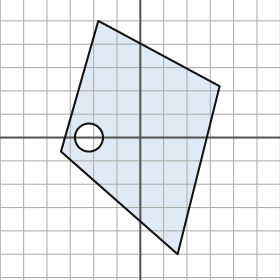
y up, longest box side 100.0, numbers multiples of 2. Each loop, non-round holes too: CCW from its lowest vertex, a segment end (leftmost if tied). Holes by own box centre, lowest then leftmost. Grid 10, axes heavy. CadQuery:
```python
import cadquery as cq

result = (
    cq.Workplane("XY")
    .moveTo(16.0, -50.0)
    .lineTo(34.0, 22.0)
    .lineTo(-18.0, 50.0)
    .lineTo(-34.0, -6.0)
    .close()
    .moveTo(-22.0, 0.0)
    .circle(6.0)
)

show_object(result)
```